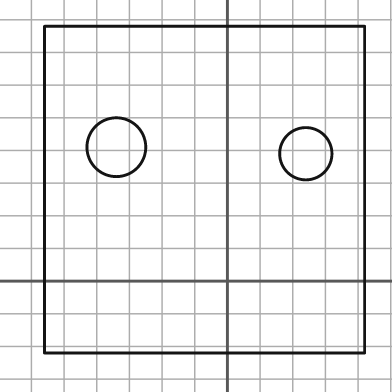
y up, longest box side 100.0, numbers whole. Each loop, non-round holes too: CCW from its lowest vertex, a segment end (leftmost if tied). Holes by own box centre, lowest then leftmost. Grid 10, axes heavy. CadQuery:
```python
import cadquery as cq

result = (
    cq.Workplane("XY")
    .moveTo(-56.0, -22.0)
    .lineTo(42.0, -22.0)
    .lineTo(42.0, 78.0)
    .lineTo(-56.0, 78.0)
    .close()
    .moveTo(24.0, 39.0)
    .circle(8.0)
    .moveTo(-34.0, 41.0)
    .circle(9.0)
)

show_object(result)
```